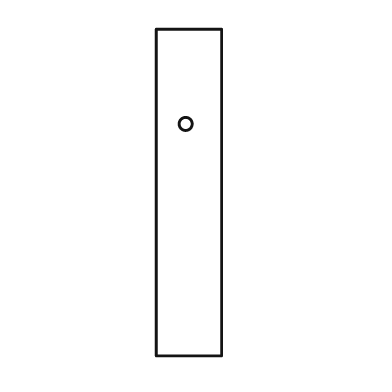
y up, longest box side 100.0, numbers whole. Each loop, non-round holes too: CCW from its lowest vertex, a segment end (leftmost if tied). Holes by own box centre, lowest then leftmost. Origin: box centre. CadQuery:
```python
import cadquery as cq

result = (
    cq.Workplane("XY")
    .moveTo(-10.0, -50.0)
    .lineTo(10.0, -50.0)
    .lineTo(10.0, 50.0)
    .lineTo(-10.0, 50.0)
    .close()
    .moveTo(-1.0, 21.0)
    .circle(2.0)
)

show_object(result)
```